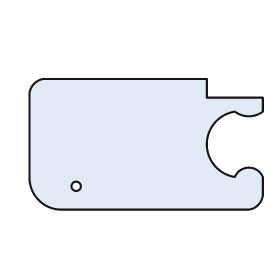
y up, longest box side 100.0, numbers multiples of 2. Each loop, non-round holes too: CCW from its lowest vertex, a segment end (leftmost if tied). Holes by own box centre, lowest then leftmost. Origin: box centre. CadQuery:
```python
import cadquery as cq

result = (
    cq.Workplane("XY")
    .moveTo(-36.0, -28.0)
    .lineTo(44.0, -28.0)
    .threePointArc((48.0, -26.0), (50.0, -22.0))
    .lineTo(50.0, -14.0)
    .threePointArc((44.0, -10.0), (38.0, -14.0))
    .threePointArc((26.0, 0.0), (38.0, 14.0))
    .threePointArc((44.0, 12.0), (50.0, 14.0))
    .lineTo(50.0, 20.0)
    .lineTo(26.0, 20.0)
    .lineTo(26.0, 28.0)
    .lineTo(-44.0, 28.0)
    .threePointArc((-48.0, 26.0), (-50.0, 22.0))
    .lineTo(-50.0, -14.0)
    .threePointArc((-46.0, -24.0), (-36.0, -28.0))
    .close()
    .moveTo(-30.0, -18.0)
    .circle(2.0)
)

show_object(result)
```